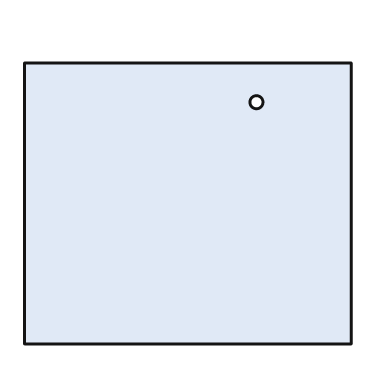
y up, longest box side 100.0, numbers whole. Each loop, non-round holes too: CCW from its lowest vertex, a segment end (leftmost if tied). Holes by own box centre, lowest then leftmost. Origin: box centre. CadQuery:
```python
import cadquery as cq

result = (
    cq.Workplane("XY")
    .moveTo(-50.0, -43.0)
    .lineTo(50.0, -43.0)
    .lineTo(50.0, 43.0)
    .lineTo(-50.0, 43.0)
    .close()
    .moveTo(21.0, 31.0)
    .circle(2.0)
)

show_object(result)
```